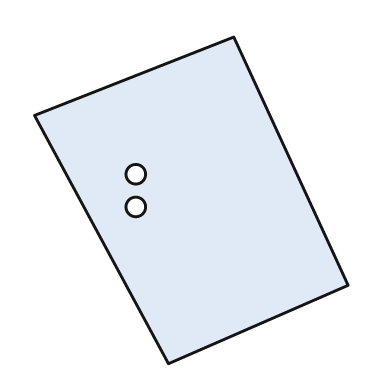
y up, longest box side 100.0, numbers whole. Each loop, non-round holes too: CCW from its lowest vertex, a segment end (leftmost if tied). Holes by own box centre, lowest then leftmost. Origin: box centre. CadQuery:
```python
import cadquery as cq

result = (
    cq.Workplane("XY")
    .moveTo(-7.0, -50.0)
    .lineTo(48.0, -26.0)
    .lineTo(13.0, 50.0)
    .lineTo(-48.0, 26.0)
    .close()
    .moveTo(-17.0, -2.0)
    .circle(3.0)
    .moveTo(-17.0, 8.0)
    .circle(3.0)
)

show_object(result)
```